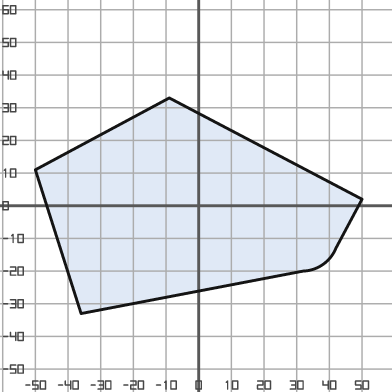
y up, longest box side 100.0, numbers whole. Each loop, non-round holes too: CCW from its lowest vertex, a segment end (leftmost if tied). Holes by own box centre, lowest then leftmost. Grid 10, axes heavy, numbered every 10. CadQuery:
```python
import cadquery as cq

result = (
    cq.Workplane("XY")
    .moveTo(-36.0, -33.0)
    .lineTo(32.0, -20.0)
    .threePointArc((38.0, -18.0), (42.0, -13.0))
    .lineTo(50.0, 2.0)
    .lineTo(-9.0, 33.0)
    .lineTo(-50.0, 11.0)
    .close()
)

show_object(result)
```